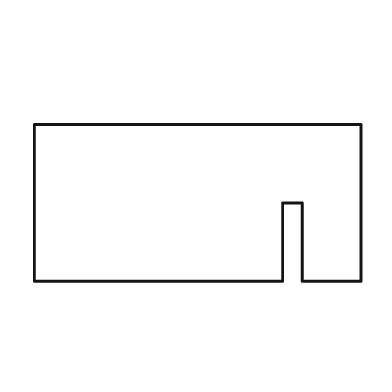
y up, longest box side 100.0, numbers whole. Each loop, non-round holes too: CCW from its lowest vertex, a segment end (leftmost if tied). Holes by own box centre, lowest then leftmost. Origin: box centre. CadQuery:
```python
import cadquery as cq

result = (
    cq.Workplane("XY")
    .moveTo(-50.0, -24.0)
    .lineTo(26.0, -24.0)
    .lineTo(26.0, 0.0)
    .lineTo(32.0, 0.0)
    .lineTo(32.0, -24.0)
    .lineTo(50.0, -24.0)
    .lineTo(50.0, 24.0)
    .lineTo(-50.0, 24.0)
    .close()
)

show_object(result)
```